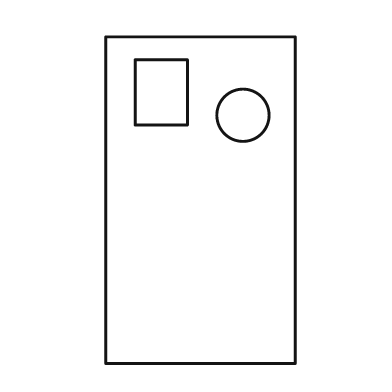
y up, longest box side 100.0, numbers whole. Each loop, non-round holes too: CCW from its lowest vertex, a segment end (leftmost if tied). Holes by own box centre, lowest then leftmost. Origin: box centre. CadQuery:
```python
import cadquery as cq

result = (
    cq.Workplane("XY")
    .moveTo(-29.0, -50.0)
    .lineTo(29.0, -50.0)
    .lineTo(29.0, 50.0)
    .lineTo(-29.0, 50.0)
    .close()
    .moveTo(13.0, 26.0)
    .circle(8.0)
    .moveTo(-20.0, 23.0)
    .lineTo(-4.0, 23.0)
    .lineTo(-4.0, 43.0)
    .lineTo(-20.0, 43.0)
    .close()
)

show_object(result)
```